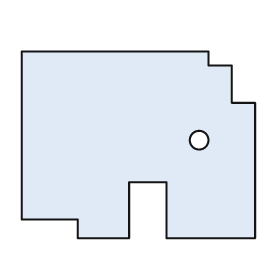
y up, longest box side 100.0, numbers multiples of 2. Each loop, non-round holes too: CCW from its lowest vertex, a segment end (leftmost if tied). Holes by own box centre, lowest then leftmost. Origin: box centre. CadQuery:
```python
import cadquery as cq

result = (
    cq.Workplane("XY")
    .moveTo(-26.0, -40.0)
    .lineTo(-4.0, -40.0)
    .lineTo(-4.0, -16.0)
    .lineTo(12.0, -16.0)
    .lineTo(12.0, -40.0)
    .lineTo(50.0, -40.0)
    .lineTo(50.0, 18.0)
    .lineTo(40.0, 18.0)
    .lineTo(40.0, 34.0)
    .lineTo(30.0, 34.0)
    .lineTo(30.0, 40.0)
    .lineTo(-50.0, 40.0)
    .lineTo(-50.0, -32.0)
    .lineTo(-26.0, -32.0)
    .close()
    .moveTo(26.0, 2.0)
    .circle(4.0)
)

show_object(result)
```